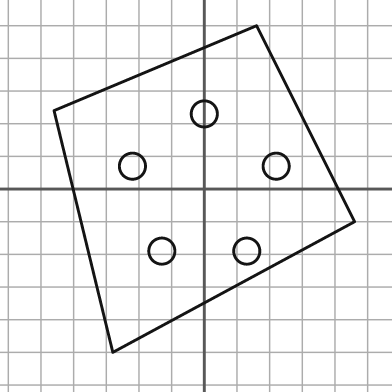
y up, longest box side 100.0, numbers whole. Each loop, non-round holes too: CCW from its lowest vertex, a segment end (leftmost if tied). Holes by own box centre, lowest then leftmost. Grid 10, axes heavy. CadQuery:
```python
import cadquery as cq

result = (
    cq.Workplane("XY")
    .moveTo(-28.0, -50.0)
    .lineTo(46.0, -10.0)
    .lineTo(16.0, 50.0)
    .lineTo(-46.0, 24.0)
    .close()
    .moveTo(-13.0, -19.0)
    .circle(4.0)
    .moveTo(13.0, -19.0)
    .circle(4.0)
    .moveTo(-22.0, 7.0)
    .circle(4.0)
    .moveTo(22.0, 7.0)
    .circle(4.0)
    .moveTo(0.0, 23.0)
    .circle(4.0)
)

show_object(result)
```